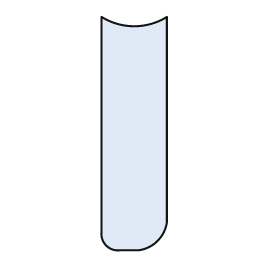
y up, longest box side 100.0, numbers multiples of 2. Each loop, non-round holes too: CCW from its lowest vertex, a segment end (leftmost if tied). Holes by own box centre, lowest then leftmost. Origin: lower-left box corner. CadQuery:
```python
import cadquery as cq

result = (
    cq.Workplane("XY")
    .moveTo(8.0, 0.0)
    .lineTo(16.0, 0.0)
    .threePointArc((24.0, 4.0), (28.0, 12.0))
    .lineTo(28.0, 100.0)
    .threePointArc((14.0, 96.0), (0.0, 100.0))
    .lineTo(0.0, 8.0)
    .threePointArc((2.0, 2.0), (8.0, 0.0))
    .close()
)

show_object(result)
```